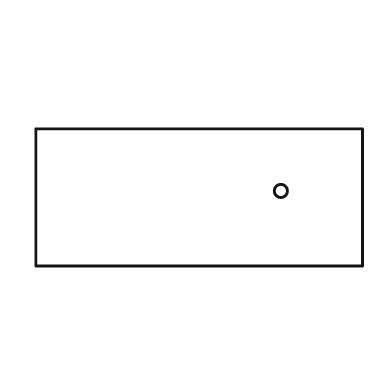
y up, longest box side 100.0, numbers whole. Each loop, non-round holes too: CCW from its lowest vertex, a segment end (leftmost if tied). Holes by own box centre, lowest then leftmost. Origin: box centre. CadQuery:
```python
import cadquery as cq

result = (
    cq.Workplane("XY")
    .moveTo(-50.0, -21.0)
    .lineTo(50.0, -21.0)
    .lineTo(50.0, 21.0)
    .lineTo(-50.0, 21.0)
    .close()
    .moveTo(25.0, 2.0)
    .circle(2.0)
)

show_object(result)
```